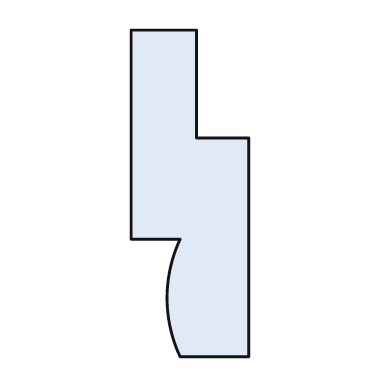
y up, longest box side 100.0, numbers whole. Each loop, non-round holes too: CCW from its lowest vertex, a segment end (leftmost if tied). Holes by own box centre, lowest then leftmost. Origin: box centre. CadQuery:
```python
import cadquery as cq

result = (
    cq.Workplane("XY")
    .moveTo(-3.0, -50.0)
    .lineTo(18.0, -50.0)
    .lineTo(18.0, 17.0)
    .lineTo(2.0, 17.0)
    .lineTo(2.0, 50.0)
    .lineTo(-18.0, 50.0)
    .lineTo(-18.0, -14.0)
    .lineTo(-3.0, -14.0)
    .threePointArc((-7.0, -32.0), (-3.0, -50.0))
    .close()
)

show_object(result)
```